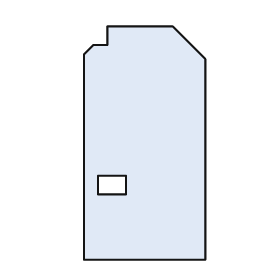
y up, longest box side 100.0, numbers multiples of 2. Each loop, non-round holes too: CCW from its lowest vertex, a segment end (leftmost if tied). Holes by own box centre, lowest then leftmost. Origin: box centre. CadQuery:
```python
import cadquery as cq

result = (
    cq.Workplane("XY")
    .moveTo(-26.0, -50.0)
    .lineTo(26.0, -50.0)
    .lineTo(26.0, 36.0)
    .lineTo(12.0, 50.0)
    .lineTo(-16.0, 50.0)
    .lineTo(-16.0, 42.0)
    .lineTo(-22.0, 42.0)
    .lineTo(-26.0, 38.0)
    .close()
    .moveTo(-20.0, -22.0)
    .lineTo(-8.0, -22.0)
    .lineTo(-8.0, -14.0)
    .lineTo(-20.0, -14.0)
    .close()
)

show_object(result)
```